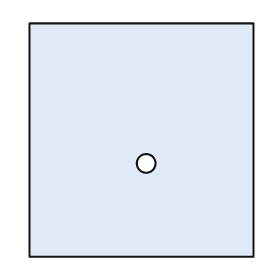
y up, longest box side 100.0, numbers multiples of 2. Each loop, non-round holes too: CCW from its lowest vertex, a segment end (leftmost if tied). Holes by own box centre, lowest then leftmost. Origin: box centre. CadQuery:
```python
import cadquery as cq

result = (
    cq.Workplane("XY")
    .moveTo(-48.0, -50.0)
    .lineTo(48.0, -50.0)
    .lineTo(48.0, 50.0)
    .lineTo(-48.0, 50.0)
    .close()
    .moveTo(2.0, -10.0)
    .circle(4.0)
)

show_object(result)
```